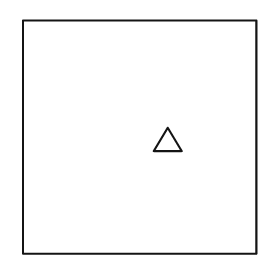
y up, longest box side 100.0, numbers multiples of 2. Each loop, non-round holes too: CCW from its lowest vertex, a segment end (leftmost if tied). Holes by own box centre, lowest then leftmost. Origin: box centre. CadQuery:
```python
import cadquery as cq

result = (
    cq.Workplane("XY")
    .moveTo(-50.0, -50.0)
    .lineTo(50.0, -50.0)
    .lineTo(50.0, 50.0)
    .lineTo(-50.0, 50.0)
    .close()
    .moveTo(6.0, -6.0)
    .lineTo(18.0, -6.0)
    .lineTo(12.0, 4.0)
    .close()
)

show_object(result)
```